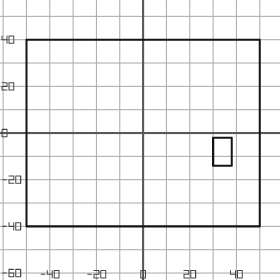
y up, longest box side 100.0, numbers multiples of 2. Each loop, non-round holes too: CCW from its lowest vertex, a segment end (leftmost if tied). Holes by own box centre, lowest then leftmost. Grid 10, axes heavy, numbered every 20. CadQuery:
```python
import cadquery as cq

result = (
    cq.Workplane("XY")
    .moveTo(-50.0, -40.0)
    .lineTo(50.0, -40.0)
    .lineTo(50.0, 40.0)
    .lineTo(-50.0, 40.0)
    .close()
    .moveTo(30.0, -14.0)
    .lineTo(38.0, -14.0)
    .lineTo(38.0, -2.0)
    .lineTo(30.0, -2.0)
    .close()
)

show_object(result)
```